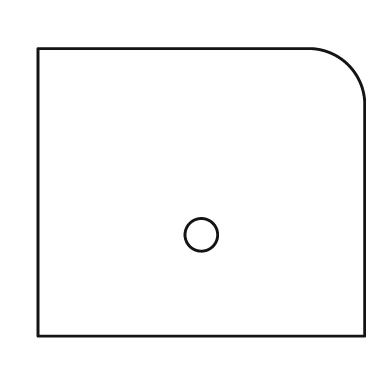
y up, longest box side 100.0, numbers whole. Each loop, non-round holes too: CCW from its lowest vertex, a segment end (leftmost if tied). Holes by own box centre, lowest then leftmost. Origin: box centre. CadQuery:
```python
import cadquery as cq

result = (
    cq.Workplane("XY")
    .moveTo(-50.0, -44.0)
    .lineTo(50.0, -44.0)
    .lineTo(50.0, 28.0)
    .threePointArc((45.0, 39.0), (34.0, 44.0))
    .lineTo(-50.0, 44.0)
    .close()
    .moveTo(0.0, -13.0)
    .circle(5.0)
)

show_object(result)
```